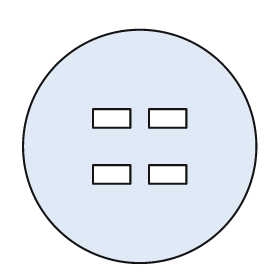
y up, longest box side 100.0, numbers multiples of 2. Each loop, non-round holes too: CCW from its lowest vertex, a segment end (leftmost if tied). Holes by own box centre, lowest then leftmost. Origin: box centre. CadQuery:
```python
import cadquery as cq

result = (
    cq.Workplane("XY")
    .moveTo(0.0, 0.0)
    .circle(50.0)
    .moveTo(-20.0, -16.0)
    .lineTo(-4.0, -16.0)
    .lineTo(-4.0, -8.0)
    .lineTo(-20.0, -8.0)
    .close()
    .moveTo(4.0, -16.0)
    .lineTo(20.0, -16.0)
    .lineTo(20.0, -8.0)
    .lineTo(4.0, -8.0)
    .close()
    .moveTo(-20.0, 8.0)
    .lineTo(-4.0, 8.0)
    .lineTo(-4.0, 16.0)
    .lineTo(-20.0, 16.0)
    .close()
    .moveTo(4.0, 8.0)
    .lineTo(20.0, 8.0)
    .lineTo(20.0, 16.0)
    .lineTo(4.0, 16.0)
    .close()
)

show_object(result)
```